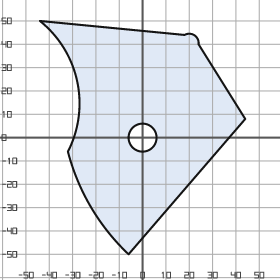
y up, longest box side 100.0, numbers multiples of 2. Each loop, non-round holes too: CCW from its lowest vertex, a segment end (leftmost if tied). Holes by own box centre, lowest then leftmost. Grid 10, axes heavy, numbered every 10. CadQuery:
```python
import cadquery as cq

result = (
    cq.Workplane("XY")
    .moveTo(-6.0, -50.0)
    .lineTo(44.0, 8.0)
    .lineTo(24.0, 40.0)
    .threePointArc((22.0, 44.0), (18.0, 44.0))
    .lineTo(-44.0, 50.0)
    .threePointArc((-28.0, 24.0), (-32.0, -6.0))
    .threePointArc((-22.0, -30.0), (-6.0, -50.0))
    .close()
    .moveTo(0.0, 0.0)
    .circle(6.0)
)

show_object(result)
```